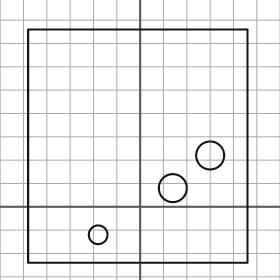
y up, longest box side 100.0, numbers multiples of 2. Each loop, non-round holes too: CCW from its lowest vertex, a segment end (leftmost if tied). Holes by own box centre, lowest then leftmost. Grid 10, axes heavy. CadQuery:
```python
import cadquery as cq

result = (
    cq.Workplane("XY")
    .moveTo(-48.0, -24.0)
    .lineTo(46.0, -24.0)
    .lineTo(46.0, 76.0)
    .lineTo(-48.0, 76.0)
    .close()
    .moveTo(-18.0, -12.0)
    .circle(4.0)
    .moveTo(14.0, 8.0)
    .circle(6.0)
    .moveTo(30.0, 22.0)
    .circle(6.0)
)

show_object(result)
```